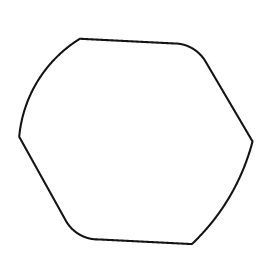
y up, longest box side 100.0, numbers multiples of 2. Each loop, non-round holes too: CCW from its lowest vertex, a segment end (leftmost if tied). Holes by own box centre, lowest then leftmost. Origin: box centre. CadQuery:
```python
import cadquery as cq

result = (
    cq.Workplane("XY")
    .moveTo(24.0, -44.0)
    .threePointArc((40.0, -24.0), (50.0, 0.0))
    .lineTo(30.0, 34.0)
    .threePointArc((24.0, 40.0), (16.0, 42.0))
    .lineTo(-24.0, 44.0)
    .threePointArc((-42.0, 26.0), (-50.0, 2.0))
    .lineTo(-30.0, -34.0)
    .threePointArc((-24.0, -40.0), (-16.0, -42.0))
    .close()
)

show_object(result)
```